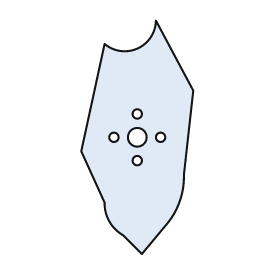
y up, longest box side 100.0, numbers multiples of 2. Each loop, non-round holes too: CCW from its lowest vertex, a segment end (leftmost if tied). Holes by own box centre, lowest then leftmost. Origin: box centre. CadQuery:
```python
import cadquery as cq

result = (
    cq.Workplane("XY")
    .moveTo(2.0, -50.0)
    .lineTo(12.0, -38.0)
    .threePointArc((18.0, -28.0), (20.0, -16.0))
    .lineTo(24.0, 20.0)
    .lineTo(8.0, 50.0)
    .threePointArc((0.0, 38.0), (-14.0, 40.0))
    .lineTo(-24.0, -6.0)
    .lineTo(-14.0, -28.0)
    .threePointArc((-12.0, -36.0), (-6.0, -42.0))
    .close()
    .moveTo(0.0, -10.0)
    .circle(2.0)
    .moveTo(-10.0, 0.0)
    .circle(2.0)
    .moveTo(0.0, 0.0)
    .circle(4.0)
    .moveTo(10.0, 0.0)
    .circle(2.0)
    .moveTo(0.0, 10.0)
    .circle(2.0)
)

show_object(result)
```